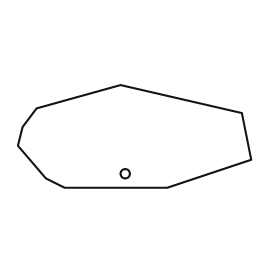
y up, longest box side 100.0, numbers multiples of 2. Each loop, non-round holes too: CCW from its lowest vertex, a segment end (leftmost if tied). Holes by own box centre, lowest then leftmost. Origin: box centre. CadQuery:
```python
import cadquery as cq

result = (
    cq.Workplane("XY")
    .moveTo(-30.0, -22.0)
    .lineTo(14.0, -22.0)
    .lineTo(50.0, -10.0)
    .lineTo(46.0, 10.0)
    .lineTo(-6.0, 22.0)
    .lineTo(-42.0, 12.0)
    .lineTo(-48.0, 4.0)
    .lineTo(-50.0, -4.0)
    .lineTo(-38.0, -18.0)
    .close()
    .moveTo(-4.0, -16.0)
    .circle(2.0)
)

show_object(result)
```